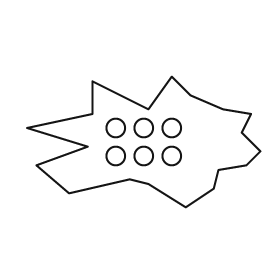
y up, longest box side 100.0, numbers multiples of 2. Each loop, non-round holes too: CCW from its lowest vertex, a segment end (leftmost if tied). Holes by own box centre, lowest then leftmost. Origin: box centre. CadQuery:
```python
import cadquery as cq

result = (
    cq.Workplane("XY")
    .moveTo(18.0, -28.0)
    .lineTo(30.0, -20.0)
    .lineTo(32.0, -12.0)
    .lineTo(44.0, -10.0)
    .lineTo(50.0, -4.0)
    .lineTo(42.0, 4.0)
    .lineTo(46.0, 12.0)
    .lineTo(34.0, 14.0)
    .lineTo(20.0, 20.0)
    .lineTo(12.0, 28.0)
    .lineTo(2.0, 14.0)
    .lineTo(-22.0, 26.0)
    .lineTo(-22.0, 12.0)
    .lineTo(-50.0, 6.0)
    .lineTo(-24.0, -2.0)
    .lineTo(-46.0, -10.0)
    .lineTo(-32.0, -22.0)
    .lineTo(-6.0, -16.0)
    .lineTo(2.0, -18.0)
    .close()
    .moveTo(-12.0, -6.0)
    .circle(4.0)
    .moveTo(0.0, -6.0)
    .circle(4.0)
    .moveTo(12.0, -6.0)
    .circle(4.0)
    .moveTo(-12.0, 6.0)
    .circle(4.0)
    .moveTo(0.0, 6.0)
    .circle(4.0)
    .moveTo(12.0, 6.0)
    .circle(4.0)
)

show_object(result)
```